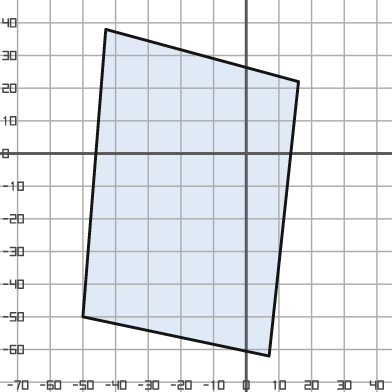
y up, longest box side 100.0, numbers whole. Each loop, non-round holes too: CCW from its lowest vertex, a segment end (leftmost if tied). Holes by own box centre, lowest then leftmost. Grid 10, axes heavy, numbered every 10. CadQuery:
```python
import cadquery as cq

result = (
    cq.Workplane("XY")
    .moveTo(7.0, -62.0)
    .lineTo(16.0, 22.0)
    .lineTo(-43.0, 38.0)
    .lineTo(-50.0, -50.0)
    .close()
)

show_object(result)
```